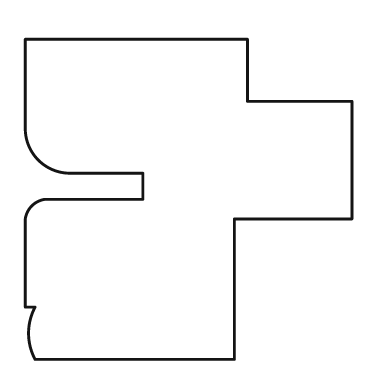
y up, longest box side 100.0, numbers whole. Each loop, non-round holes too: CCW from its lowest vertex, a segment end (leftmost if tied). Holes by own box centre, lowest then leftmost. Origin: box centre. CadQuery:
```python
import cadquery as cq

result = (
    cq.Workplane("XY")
    .moveTo(-47.0, -49.0)
    .lineTo(14.0, -49.0)
    .lineTo(14.0, -6.0)
    .lineTo(50.0, -6.0)
    .lineTo(50.0, 30.0)
    .lineTo(18.0, 30.0)
    .lineTo(18.0, 49.0)
    .lineTo(-50.0, 49.0)
    .lineTo(-50.0, 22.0)
    .threePointArc((-46.0, 12.0), (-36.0, 8.0))
    .lineTo(-14.0, 8.0)
    .lineTo(-14.0, 0.0)
    .lineTo(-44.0, 0.0)
    .threePointArc((-48.0, -2.0), (-50.0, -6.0))
    .lineTo(-50.0, -33.0)
    .lineTo(-47.0, -33.0)
    .threePointArc((-49.0, -41.0), (-47.0, -49.0))
    .close()
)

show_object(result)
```